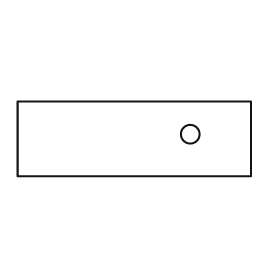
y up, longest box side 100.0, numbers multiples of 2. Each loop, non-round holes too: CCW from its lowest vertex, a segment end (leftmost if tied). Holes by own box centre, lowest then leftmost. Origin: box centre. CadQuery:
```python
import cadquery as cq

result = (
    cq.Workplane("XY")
    .moveTo(-50.0, -16.0)
    .lineTo(50.0, -16.0)
    .lineTo(50.0, 16.0)
    .lineTo(-50.0, 16.0)
    .close()
    .moveTo(24.0, 2.0)
    .circle(4.0)
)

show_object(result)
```